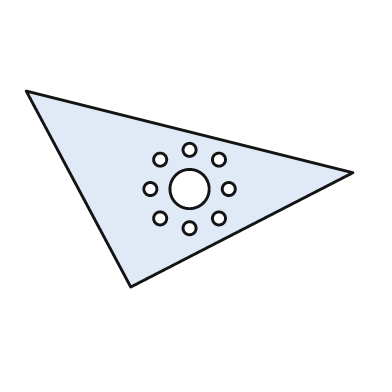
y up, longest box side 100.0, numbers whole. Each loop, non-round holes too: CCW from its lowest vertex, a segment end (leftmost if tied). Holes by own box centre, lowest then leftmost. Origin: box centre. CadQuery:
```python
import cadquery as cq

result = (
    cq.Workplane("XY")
    .moveTo(-18.0, -30.0)
    .lineTo(50.0, 5.0)
    .lineTo(-50.0, 30.0)
    .close()
    .moveTo(0.0, -12.0)
    .circle(2.0)
    .moveTo(-9.0, -9.0)
    .circle(2.0)
    .moveTo(9.0, -9.0)
    .circle(2.0)
    .moveTo(-12.0, 0.0)
    .circle(2.0)
    .moveTo(0.0, 0.0)
    .circle(6.0)
    .moveTo(12.0, 0.0)
    .circle(2.0)
    .moveTo(-9.0, 9.0)
    .circle(2.0)
    .moveTo(9.0, 9.0)
    .circle(2.0)
    .moveTo(0.0, 12.0)
    .circle(2.0)
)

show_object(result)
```